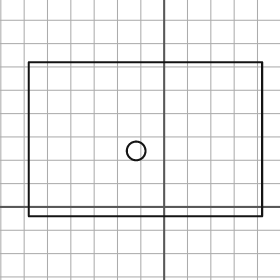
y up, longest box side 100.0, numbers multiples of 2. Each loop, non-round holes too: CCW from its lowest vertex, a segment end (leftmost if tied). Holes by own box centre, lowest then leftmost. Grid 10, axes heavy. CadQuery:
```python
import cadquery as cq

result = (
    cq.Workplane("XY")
    .moveTo(-58.0, -4.0)
    .lineTo(42.0, -4.0)
    .lineTo(42.0, 62.0)
    .lineTo(-58.0, 62.0)
    .close()
    .moveTo(-12.0, 24.0)
    .circle(4.0)
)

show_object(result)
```